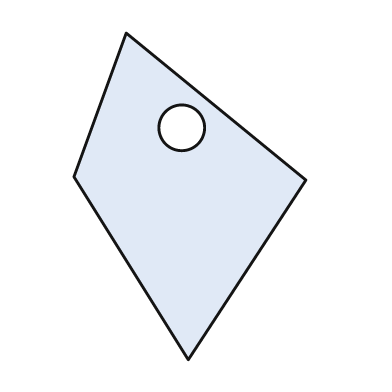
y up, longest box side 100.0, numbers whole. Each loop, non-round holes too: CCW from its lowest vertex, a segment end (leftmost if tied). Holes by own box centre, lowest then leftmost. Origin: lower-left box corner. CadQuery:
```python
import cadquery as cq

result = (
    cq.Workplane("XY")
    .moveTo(35.0, 0.0)
    .lineTo(71.0, 55.0)
    .lineTo(16.0, 100.0)
    .lineTo(0.0, 56.0)
    .close()
    .moveTo(33.0, 71.0)
    .circle(7.0)
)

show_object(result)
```